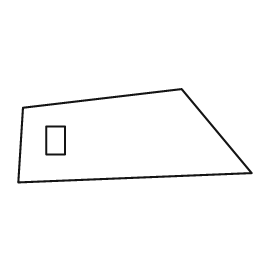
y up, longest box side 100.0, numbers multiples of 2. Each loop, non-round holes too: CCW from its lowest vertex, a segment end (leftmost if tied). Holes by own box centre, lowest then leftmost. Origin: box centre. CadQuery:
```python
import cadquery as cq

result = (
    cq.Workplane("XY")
    .moveTo(-50.0, -20.0)
    .lineTo(50.0, -16.0)
    .lineTo(20.0, 20.0)
    .lineTo(-48.0, 12.0)
    .close()
    .moveTo(-38.0, -8.0)
    .lineTo(-30.0, -8.0)
    .lineTo(-30.0, 4.0)
    .lineTo(-38.0, 4.0)
    .close()
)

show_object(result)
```